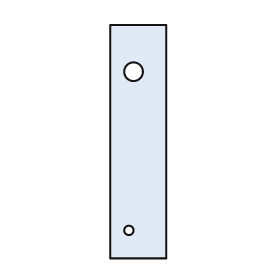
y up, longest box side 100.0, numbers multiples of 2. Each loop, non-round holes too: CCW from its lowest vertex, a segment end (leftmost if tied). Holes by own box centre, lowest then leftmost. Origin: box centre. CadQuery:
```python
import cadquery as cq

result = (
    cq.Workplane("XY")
    .moveTo(-12.0, -50.0)
    .lineTo(12.0, -50.0)
    .lineTo(12.0, 50.0)
    .lineTo(-12.0, 50.0)
    .close()
    .moveTo(-4.0, -38.0)
    .circle(2.0)
    .moveTo(-2.0, 30.0)
    .circle(4.0)
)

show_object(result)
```